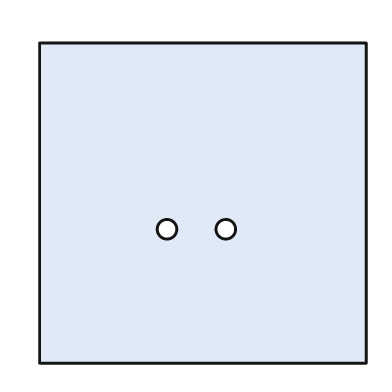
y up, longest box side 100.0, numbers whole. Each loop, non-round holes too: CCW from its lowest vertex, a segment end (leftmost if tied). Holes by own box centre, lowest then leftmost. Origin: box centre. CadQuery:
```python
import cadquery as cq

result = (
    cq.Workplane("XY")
    .moveTo(-50.0, -49.0)
    .lineTo(50.0, -49.0)
    .lineTo(50.0, 49.0)
    .lineTo(-50.0, 49.0)
    .close()
    .moveTo(-11.0, -8.0)
    .circle(3.0)
    .moveTo(7.0, -8.0)
    .circle(3.0)
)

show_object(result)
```